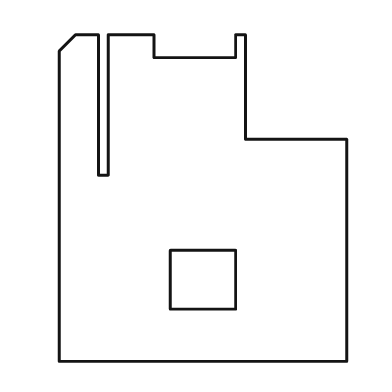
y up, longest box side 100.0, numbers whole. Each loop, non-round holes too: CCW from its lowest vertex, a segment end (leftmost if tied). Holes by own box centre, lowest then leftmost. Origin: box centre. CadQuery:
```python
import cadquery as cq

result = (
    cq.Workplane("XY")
    .moveTo(-44.0, -50.0)
    .lineTo(44.0, -50.0)
    .lineTo(44.0, 18.0)
    .lineTo(13.0, 18.0)
    .lineTo(13.0, 50.0)
    .lineTo(10.0, 50.0)
    .lineTo(10.0, 43.0)
    .lineTo(-15.0, 43.0)
    .lineTo(-15.0, 50.0)
    .lineTo(-29.0, 50.0)
    .lineTo(-29.0, 7.0)
    .lineTo(-32.0, 7.0)
    .lineTo(-32.0, 50.0)
    .lineTo(-39.0, 50.0)
    .lineTo(-44.0, 45.0)
    .close()
    .moveTo(-10.0, -34.0)
    .lineTo(10.0, -34.0)
    .lineTo(10.0, -16.0)
    .lineTo(-10.0, -16.0)
    .close()
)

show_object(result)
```